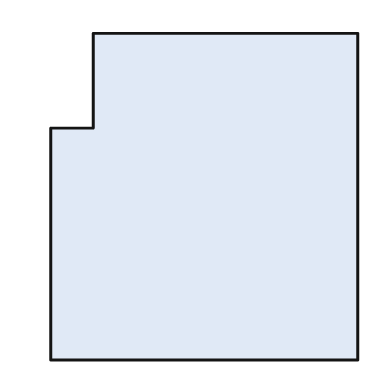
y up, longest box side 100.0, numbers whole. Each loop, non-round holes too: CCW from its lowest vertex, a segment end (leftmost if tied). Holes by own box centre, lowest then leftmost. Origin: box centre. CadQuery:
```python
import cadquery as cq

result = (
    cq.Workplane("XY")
    .moveTo(-47.0, -50.0)
    .lineTo(47.0, -50.0)
    .lineTo(47.0, 50.0)
    .lineTo(-34.0, 50.0)
    .lineTo(-34.0, 21.0)
    .lineTo(-47.0, 21.0)
    .close()
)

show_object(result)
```